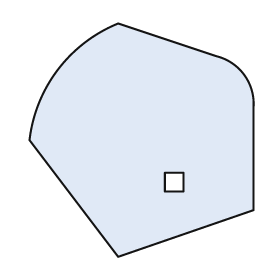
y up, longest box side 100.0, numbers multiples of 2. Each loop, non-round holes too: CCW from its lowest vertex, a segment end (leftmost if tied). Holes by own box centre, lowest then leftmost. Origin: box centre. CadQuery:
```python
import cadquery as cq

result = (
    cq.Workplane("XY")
    .moveTo(-10.0, -50.0)
    .lineTo(48.0, -30.0)
    .lineTo(48.0, 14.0)
    .threePointArc((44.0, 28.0), (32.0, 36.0))
    .lineTo(-10.0, 50.0)
    .threePointArc((-36.0, 30.0), (-48.0, 0.0))
    .close()
    .moveTo(10.0, -22.0)
    .lineTo(18.0, -22.0)
    .lineTo(18.0, -14.0)
    .lineTo(10.0, -14.0)
    .close()
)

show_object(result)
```